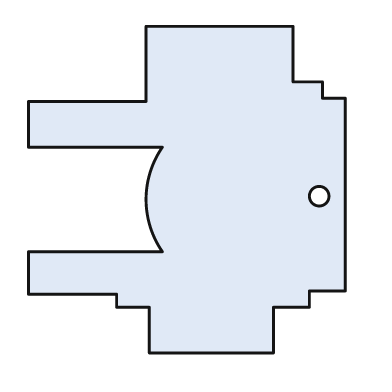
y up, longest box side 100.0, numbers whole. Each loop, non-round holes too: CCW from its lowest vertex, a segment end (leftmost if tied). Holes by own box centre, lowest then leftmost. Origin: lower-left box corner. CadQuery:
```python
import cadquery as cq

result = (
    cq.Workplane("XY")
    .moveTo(37.0, 0.0)
    .lineTo(75.0, 0.0)
    .lineTo(75.0, 14.0)
    .lineTo(86.0, 14.0)
    .lineTo(86.0, 19.0)
    .lineTo(97.0, 19.0)
    .lineTo(97.0, 78.0)
    .lineTo(90.0, 78.0)
    .lineTo(90.0, 83.0)
    .lineTo(81.0, 83.0)
    .lineTo(81.0, 100.0)
    .lineTo(36.0, 100.0)
    .lineTo(36.0, 77.0)
    .lineTo(0.0, 77.0)
    .lineTo(0.0, 63.0)
    .lineTo(41.0, 63.0)
    .threePointArc((36.0, 47.0), (41.0, 31.0))
    .lineTo(0.0, 31.0)
    .lineTo(0.0, 18.0)
    .lineTo(27.0, 18.0)
    .lineTo(27.0, 14.0)
    .lineTo(37.0, 14.0)
    .close()
    .moveTo(89.0, 48.0)
    .circle(3.0)
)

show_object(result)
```